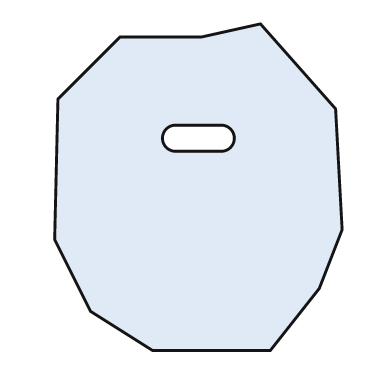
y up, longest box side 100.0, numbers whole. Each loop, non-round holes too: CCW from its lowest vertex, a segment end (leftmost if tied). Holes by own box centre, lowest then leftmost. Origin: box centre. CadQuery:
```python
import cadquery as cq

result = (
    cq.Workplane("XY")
    .moveTo(-14.0, -50.0)
    .lineTo(22.0, -50.0)
    .lineTo(37.0, -31.0)
    .lineTo(44.0, -13.0)
    .lineTo(42.0, 24.0)
    .lineTo(19.0, 50.0)
    .lineTo(1.0, 46.0)
    .lineTo(-24.0, 46.0)
    .lineTo(-43.0, 27.0)
    .lineTo(-44.0, -16.0)
    .lineTo(-33.0, -38.0)
    .close()
    .moveTo(-7.0, 11.0)
    .lineTo(7.0, 11.0)
    .threePointArc((11.0, 15.0), (7.0, 19.0))
    .lineTo(-7.0, 19.0)
    .threePointArc((-11.0, 15.0), (-7.0, 11.0))
    .close()
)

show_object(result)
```